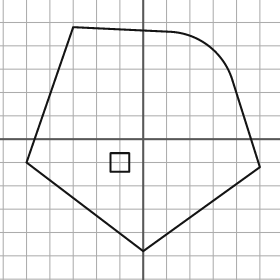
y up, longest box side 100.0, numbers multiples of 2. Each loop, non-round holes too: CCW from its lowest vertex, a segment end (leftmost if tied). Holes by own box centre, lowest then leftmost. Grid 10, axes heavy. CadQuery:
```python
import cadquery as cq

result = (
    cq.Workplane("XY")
    .moveTo(0.0, -48.0)
    .lineTo(50.0, -12.0)
    .lineTo(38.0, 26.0)
    .threePointArc((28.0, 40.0), (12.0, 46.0))
    .lineTo(-30.0, 48.0)
    .lineTo(-50.0, -10.0)
    .close()
    .moveTo(-14.0, -14.0)
    .lineTo(-6.0, -14.0)
    .lineTo(-6.0, -6.0)
    .lineTo(-14.0, -6.0)
    .close()
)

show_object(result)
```